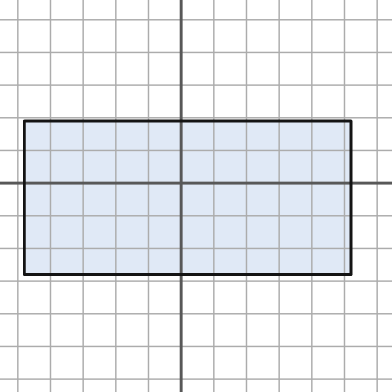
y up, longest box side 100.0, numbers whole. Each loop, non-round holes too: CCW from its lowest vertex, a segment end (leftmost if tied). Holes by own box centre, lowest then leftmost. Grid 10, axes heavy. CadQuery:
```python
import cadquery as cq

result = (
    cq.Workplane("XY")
    .moveTo(-48.0, -28.0)
    .lineTo(52.0, -28.0)
    .lineTo(52.0, 19.0)
    .lineTo(-48.0, 19.0)
    .close()
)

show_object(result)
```